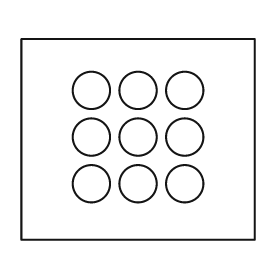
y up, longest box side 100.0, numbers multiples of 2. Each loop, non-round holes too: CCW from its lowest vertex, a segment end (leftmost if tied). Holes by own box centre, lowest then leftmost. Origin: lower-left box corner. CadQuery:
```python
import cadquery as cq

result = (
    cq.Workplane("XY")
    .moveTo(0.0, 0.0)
    .lineTo(100.0, 0.0)
    .lineTo(100.0, 86.0)
    .lineTo(0.0, 86.0)
    .close()
    .moveTo(30.0, 24.0)
    .circle(8.0)
    .moveTo(50.0, 24.0)
    .circle(8.0)
    .moveTo(70.0, 24.0)
    .circle(8.0)
    .moveTo(30.0, 44.0)
    .circle(8.0)
    .moveTo(50.0, 44.0)
    .circle(8.0)
    .moveTo(70.0, 44.0)
    .circle(8.0)
    .moveTo(30.0, 64.0)
    .circle(8.0)
    .moveTo(50.0, 64.0)
    .circle(8.0)
    .moveTo(70.0, 64.0)
    .circle(8.0)
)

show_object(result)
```